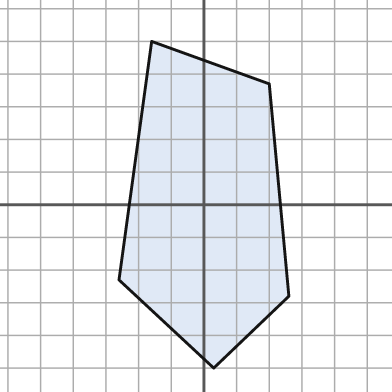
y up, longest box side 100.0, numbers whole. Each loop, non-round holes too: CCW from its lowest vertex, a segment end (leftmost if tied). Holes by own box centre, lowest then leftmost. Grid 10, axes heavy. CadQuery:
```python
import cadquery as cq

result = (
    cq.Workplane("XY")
    .moveTo(3.0, -50.0)
    .lineTo(26.0, -28.0)
    .lineTo(20.0, 37.0)
    .lineTo(-16.0, 50.0)
    .lineTo(-26.0, -23.0)
    .close()
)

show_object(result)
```